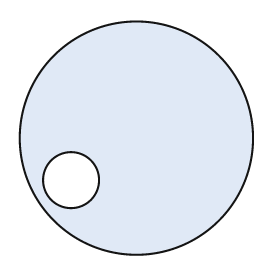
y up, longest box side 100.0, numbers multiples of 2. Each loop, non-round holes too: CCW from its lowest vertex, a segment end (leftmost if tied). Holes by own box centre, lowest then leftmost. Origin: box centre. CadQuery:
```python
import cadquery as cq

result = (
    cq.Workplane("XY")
    .moveTo(0.0, 0.0)
    .circle(50.0)
    .moveTo(-28.0, -18.0)
    .circle(12.0)
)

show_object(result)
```